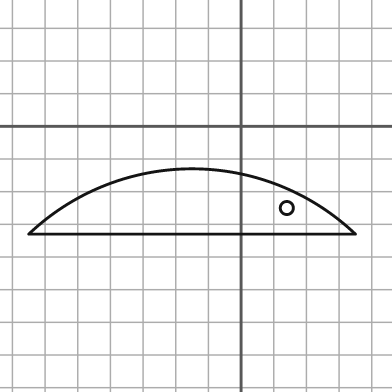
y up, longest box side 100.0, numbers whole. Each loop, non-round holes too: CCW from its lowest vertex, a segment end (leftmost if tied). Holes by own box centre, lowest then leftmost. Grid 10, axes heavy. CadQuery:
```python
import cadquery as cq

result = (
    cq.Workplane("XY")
    .moveTo(-65.0, -33.0)
    .lineTo(35.0, -33.0)
    .threePointArc((-15.0, -13.0), (-65.0, -33.0))
    .close()
    .moveTo(14.0, -25.0)
    .circle(2.0)
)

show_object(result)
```